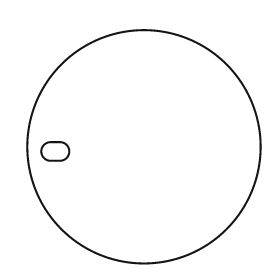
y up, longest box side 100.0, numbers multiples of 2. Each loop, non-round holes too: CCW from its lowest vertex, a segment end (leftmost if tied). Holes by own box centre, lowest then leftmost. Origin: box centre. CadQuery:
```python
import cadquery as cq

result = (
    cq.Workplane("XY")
    .moveTo(0.0, 0.0)
    .circle(50.0)
    .moveTo(-40.0, -6.0)
    .lineTo(-36.0, -6.0)
    .threePointArc((-32.0, -2.0), (-36.0, 2.0))
    .lineTo(-40.0, 2.0)
    .threePointArc((-44.0, -2.0), (-40.0, -6.0))
    .close()
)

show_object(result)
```